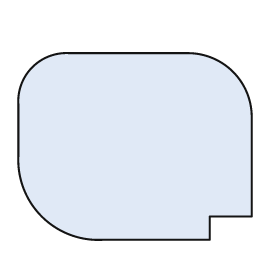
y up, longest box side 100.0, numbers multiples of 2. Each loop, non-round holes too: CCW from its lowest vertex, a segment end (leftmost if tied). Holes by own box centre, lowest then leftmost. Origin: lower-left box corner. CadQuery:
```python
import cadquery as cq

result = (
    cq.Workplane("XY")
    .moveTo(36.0, 0.0)
    .lineTo(82.0, 0.0)
    .lineTo(82.0, 10.0)
    .lineTo(100.0, 10.0)
    .lineTo(100.0, 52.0)
    .threePointArc((92.0, 72.0), (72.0, 80.0))
    .lineTo(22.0, 80.0)
    .threePointArc((6.0, 74.0), (0.0, 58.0))
    .lineTo(0.0, 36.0)
    .threePointArc((10.0, 10.0), (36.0, 0.0))
    .close()
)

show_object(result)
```